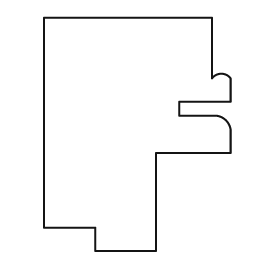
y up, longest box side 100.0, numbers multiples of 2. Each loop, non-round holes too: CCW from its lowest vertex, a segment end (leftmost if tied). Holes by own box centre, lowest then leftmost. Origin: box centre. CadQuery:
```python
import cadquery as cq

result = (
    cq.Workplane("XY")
    .moveTo(-18.0, -50.0)
    .lineTo(8.0, -50.0)
    .lineTo(8.0, -8.0)
    .lineTo(40.0, -8.0)
    .lineTo(40.0, 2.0)
    .threePointArc((38.0, 6.0), (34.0, 8.0))
    .lineTo(18.0, 8.0)
    .lineTo(18.0, 14.0)
    .lineTo(40.0, 14.0)
    .lineTo(40.0, 24.0)
    .threePointArc((36.0, 26.0), (32.0, 24.0))
    .lineTo(32.0, 50.0)
    .lineTo(-40.0, 50.0)
    .lineTo(-40.0, -40.0)
    .lineTo(-18.0, -40.0)
    .close()
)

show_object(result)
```